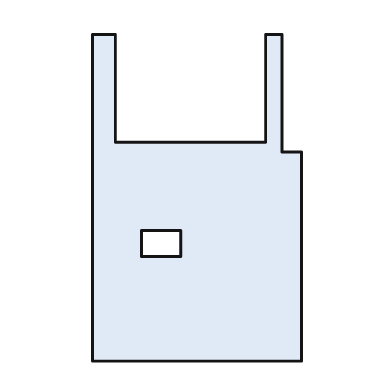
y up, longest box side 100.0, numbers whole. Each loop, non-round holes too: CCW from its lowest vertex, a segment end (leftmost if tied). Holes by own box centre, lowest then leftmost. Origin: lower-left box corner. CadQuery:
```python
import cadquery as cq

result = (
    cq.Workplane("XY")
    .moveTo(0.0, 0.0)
    .lineTo(64.0, 0.0)
    .lineTo(64.0, 64.0)
    .lineTo(58.0, 64.0)
    .lineTo(58.0, 100.0)
    .lineTo(53.0, 100.0)
    .lineTo(53.0, 67.0)
    .lineTo(7.0, 67.0)
    .lineTo(7.0, 100.0)
    .lineTo(0.0, 100.0)
    .close()
    .moveTo(15.0, 32.0)
    .lineTo(27.0, 32.0)
    .lineTo(27.0, 40.0)
    .lineTo(15.0, 40.0)
    .close()
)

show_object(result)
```